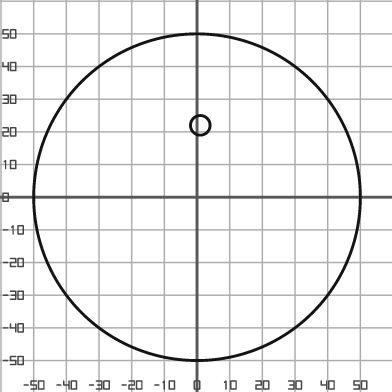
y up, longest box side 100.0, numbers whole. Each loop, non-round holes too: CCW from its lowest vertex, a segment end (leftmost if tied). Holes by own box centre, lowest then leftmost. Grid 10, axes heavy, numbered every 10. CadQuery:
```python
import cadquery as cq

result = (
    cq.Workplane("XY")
    .moveTo(0.0, 0.0)
    .circle(50.0)
    .moveTo(1.0, 22.0)
    .circle(3.0)
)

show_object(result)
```